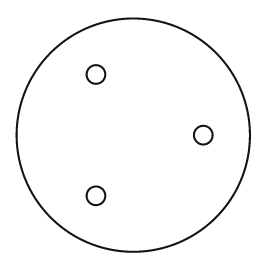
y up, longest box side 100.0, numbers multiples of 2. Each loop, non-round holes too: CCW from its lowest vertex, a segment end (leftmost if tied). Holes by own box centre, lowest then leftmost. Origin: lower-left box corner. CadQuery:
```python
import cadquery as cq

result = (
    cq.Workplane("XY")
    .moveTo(50.0, 50.0)
    .circle(50.0)
    .moveTo(34.0, 24.0)
    .circle(4.0)
    .moveTo(80.0, 50.0)
    .circle(4.0)
    .moveTo(34.0, 76.0)
    .circle(4.0)
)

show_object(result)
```